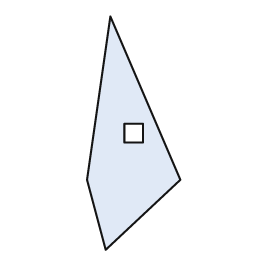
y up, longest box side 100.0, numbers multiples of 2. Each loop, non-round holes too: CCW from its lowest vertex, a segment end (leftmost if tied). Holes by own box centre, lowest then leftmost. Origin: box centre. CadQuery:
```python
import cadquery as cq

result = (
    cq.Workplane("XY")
    .moveTo(-12.0, -50.0)
    .lineTo(20.0, -20.0)
    .lineTo(-10.0, 50.0)
    .lineTo(-20.0, -20.0)
    .close()
    .moveTo(-4.0, -4.0)
    .lineTo(4.0, -4.0)
    .lineTo(4.0, 4.0)
    .lineTo(-4.0, 4.0)
    .close()
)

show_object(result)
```